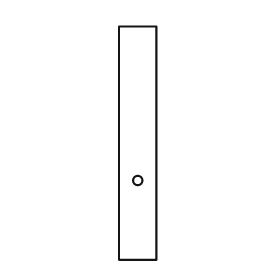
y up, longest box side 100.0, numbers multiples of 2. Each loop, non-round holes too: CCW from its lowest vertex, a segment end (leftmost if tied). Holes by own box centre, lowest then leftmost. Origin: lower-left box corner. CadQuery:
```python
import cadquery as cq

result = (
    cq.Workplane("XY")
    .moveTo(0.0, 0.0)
    .lineTo(16.0, 0.0)
    .lineTo(16.0, 100.0)
    .lineTo(0.0, 100.0)
    .close()
    .moveTo(8.0, 34.0)
    .circle(2.0)
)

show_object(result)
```